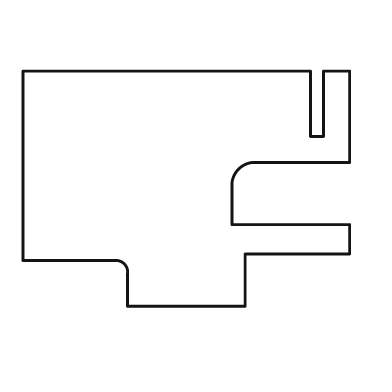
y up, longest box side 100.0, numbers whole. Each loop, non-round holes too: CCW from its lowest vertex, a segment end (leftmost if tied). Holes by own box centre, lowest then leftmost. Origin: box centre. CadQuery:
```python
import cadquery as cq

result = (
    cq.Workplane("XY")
    .moveTo(-18.0, -36.0)
    .lineTo(18.0, -36.0)
    .lineTo(18.0, -20.0)
    .lineTo(50.0, -20.0)
    .lineTo(50.0, -11.0)
    .lineTo(14.0, -11.0)
    .lineTo(14.0, 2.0)
    .threePointArc((16.0, 6.0), (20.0, 8.0))
    .lineTo(50.0, 8.0)
    .lineTo(50.0, 36.0)
    .lineTo(42.0, 36.0)
    .lineTo(42.0, 16.0)
    .lineTo(38.0, 16.0)
    .lineTo(38.0, 36.0)
    .lineTo(-50.0, 36.0)
    .lineTo(-50.0, -22.0)
    .lineTo(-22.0, -22.0)
    .threePointArc((-19.0, -23.0), (-18.0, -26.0))
    .close()
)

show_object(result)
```